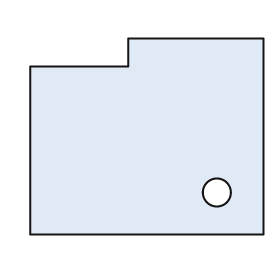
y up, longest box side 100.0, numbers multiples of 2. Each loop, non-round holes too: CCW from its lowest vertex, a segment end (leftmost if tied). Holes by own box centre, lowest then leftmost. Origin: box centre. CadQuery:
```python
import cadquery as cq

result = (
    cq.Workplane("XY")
    .moveTo(-50.0, -42.0)
    .lineTo(50.0, -42.0)
    .lineTo(50.0, 42.0)
    .lineTo(-8.0, 42.0)
    .lineTo(-8.0, 30.0)
    .lineTo(-50.0, 30.0)
    .close()
    .moveTo(30.0, -24.0)
    .circle(6.0)
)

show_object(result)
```